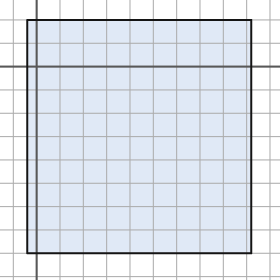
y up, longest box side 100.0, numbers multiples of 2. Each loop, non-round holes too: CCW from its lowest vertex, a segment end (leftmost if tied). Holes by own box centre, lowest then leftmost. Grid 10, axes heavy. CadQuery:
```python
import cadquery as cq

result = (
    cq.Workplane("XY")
    .moveTo(-4.0, -80.0)
    .lineTo(92.0, -80.0)
    .lineTo(92.0, 20.0)
    .lineTo(-4.0, 20.0)
    .close()
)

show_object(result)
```